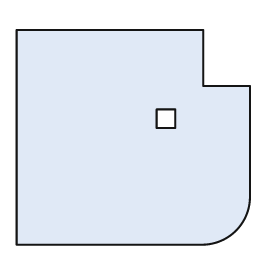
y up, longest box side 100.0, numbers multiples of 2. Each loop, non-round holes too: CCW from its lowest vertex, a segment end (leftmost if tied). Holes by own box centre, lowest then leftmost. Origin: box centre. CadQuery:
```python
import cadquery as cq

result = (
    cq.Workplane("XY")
    .moveTo(-50.0, -46.0)
    .lineTo(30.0, -46.0)
    .threePointArc((44.0, -40.0), (50.0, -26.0))
    .lineTo(50.0, 22.0)
    .lineTo(30.0, 22.0)
    .lineTo(30.0, 46.0)
    .lineTo(-50.0, 46.0)
    .close()
    .moveTo(10.0, 4.0)
    .lineTo(18.0, 4.0)
    .lineTo(18.0, 12.0)
    .lineTo(10.0, 12.0)
    .close()
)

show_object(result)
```